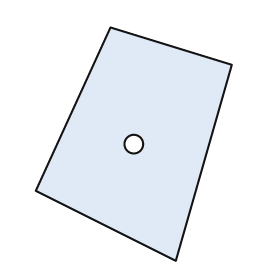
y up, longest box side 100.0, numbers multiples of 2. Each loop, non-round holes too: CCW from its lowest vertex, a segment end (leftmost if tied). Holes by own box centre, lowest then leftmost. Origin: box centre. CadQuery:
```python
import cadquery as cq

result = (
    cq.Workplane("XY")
    .moveTo(18.0, -50.0)
    .lineTo(42.0, 34.0)
    .lineTo(-10.0, 50.0)
    .lineTo(-42.0, -20.0)
    .close()
    .moveTo(0.0, 0.0)
    .circle(4.0)
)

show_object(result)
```